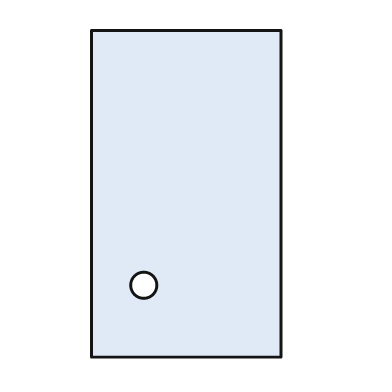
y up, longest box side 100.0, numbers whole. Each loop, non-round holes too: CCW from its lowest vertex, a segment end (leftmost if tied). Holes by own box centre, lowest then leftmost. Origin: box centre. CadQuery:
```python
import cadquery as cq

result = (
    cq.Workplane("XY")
    .moveTo(-29.0, -50.0)
    .lineTo(29.0, -50.0)
    .lineTo(29.0, 50.0)
    .lineTo(-29.0, 50.0)
    .close()
    .moveTo(-13.0, -28.0)
    .circle(4.0)
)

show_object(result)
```